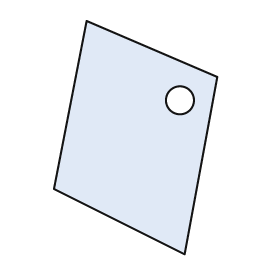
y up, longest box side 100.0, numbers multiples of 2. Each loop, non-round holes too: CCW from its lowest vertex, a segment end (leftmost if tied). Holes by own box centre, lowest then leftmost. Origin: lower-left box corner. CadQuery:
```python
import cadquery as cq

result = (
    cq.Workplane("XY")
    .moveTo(56.0, 0.0)
    .lineTo(70.0, 76.0)
    .lineTo(14.0, 100.0)
    .lineTo(0.0, 28.0)
    .close()
    .moveTo(54.0, 66.0)
    .circle(6.0)
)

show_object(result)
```